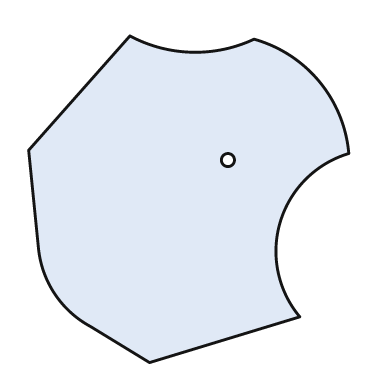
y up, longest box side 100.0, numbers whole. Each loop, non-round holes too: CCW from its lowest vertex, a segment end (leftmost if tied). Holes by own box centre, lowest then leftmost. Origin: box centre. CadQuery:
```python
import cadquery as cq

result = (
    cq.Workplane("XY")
    .moveTo(-12.0, -50.0)
    .lineTo(34.0, -36.0)
    .threePointArc((28.0, -7.0), (49.0, 14.0))
    .threePointArc((40.0, 36.0), (20.0, 49.0))
    .threePointArc((1.0, 45.0), (-18.0, 50.0))
    .lineTo(-49.0, 15.0)
    .lineTo(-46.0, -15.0)
    .threePointArc((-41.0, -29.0), (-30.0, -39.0))
    .close()
    .moveTo(12.0, 12.0)
    .circle(2.0)
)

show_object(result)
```